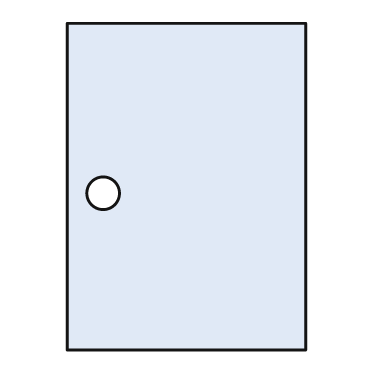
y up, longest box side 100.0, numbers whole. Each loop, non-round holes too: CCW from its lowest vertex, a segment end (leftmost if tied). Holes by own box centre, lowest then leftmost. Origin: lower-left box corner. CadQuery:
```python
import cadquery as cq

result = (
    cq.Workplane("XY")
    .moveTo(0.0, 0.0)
    .lineTo(73.0, 0.0)
    .lineTo(73.0, 100.0)
    .lineTo(0.0, 100.0)
    .close()
    .moveTo(11.0, 48.0)
    .circle(5.0)
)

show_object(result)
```